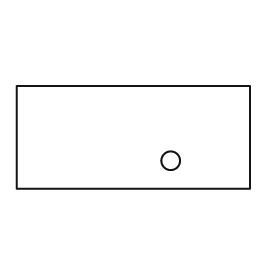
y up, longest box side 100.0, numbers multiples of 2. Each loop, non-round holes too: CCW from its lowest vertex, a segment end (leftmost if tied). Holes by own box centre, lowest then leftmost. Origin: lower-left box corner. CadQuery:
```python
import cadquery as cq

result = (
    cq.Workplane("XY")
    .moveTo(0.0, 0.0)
    .lineTo(100.0, 0.0)
    .lineTo(100.0, 44.0)
    .lineTo(0.0, 44.0)
    .close()
    .moveTo(66.0, 12.0)
    .circle(4.0)
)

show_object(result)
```